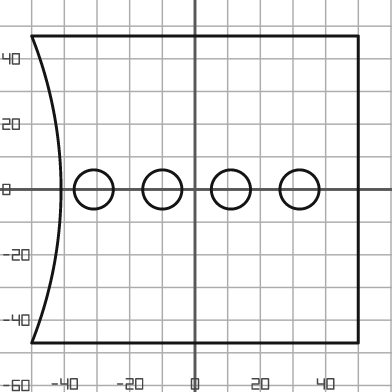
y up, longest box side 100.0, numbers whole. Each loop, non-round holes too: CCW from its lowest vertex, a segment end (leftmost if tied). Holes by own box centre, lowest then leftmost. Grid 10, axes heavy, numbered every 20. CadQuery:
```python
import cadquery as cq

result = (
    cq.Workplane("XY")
    .moveTo(-50.0, -47.0)
    .lineTo(50.0, -47.0)
    .lineTo(50.0, 47.0)
    .lineTo(-50.0, 47.0)
    .threePointArc((-41.0, 0.0), (-50.0, -47.0))
    .close()
    .moveTo(-31.0, 0.0)
    .circle(6.0)
    .moveTo(-10.0, 0.0)
    .circle(6.0)
    .moveTo(11.0, 0.0)
    .circle(6.0)
    .moveTo(32.0, 0.0)
    .circle(6.0)
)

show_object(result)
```